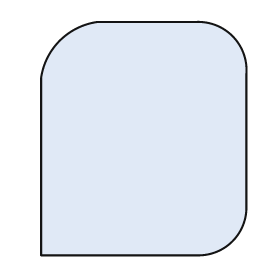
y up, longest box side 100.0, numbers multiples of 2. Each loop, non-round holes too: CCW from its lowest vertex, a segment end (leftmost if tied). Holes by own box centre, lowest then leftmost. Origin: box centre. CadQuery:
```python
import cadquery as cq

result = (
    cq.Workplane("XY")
    .moveTo(-44.0, -50.0)
    .lineTo(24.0, -50.0)
    .threePointArc((38.0, -44.0), (44.0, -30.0))
    .lineTo(44.0, 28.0)
    .threePointArc((38.0, 44.0), (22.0, 50.0))
    .lineTo(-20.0, 50.0)
    .threePointArc((-36.0, 42.0), (-44.0, 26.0))
    .close()
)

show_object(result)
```